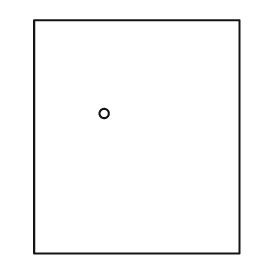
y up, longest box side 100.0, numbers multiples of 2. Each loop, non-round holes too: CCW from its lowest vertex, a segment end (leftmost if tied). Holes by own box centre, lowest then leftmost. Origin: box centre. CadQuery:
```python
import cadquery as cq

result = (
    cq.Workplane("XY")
    .moveTo(-44.0, -50.0)
    .lineTo(44.0, -50.0)
    .lineTo(44.0, 50.0)
    .lineTo(-44.0, 50.0)
    .close()
    .moveTo(-14.0, 10.0)
    .circle(2.0)
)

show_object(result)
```